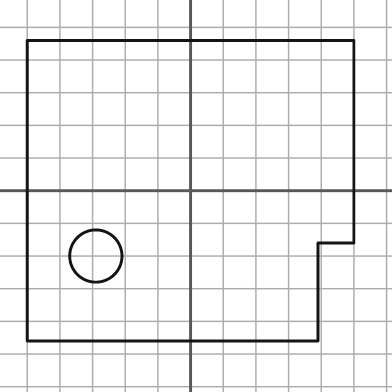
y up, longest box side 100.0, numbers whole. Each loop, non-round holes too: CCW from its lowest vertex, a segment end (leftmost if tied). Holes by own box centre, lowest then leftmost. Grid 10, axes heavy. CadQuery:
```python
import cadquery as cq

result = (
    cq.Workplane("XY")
    .moveTo(-50.0, -46.0)
    .lineTo(39.0, -46.0)
    .lineTo(39.0, -16.0)
    .lineTo(50.0, -16.0)
    .lineTo(50.0, 46.0)
    .lineTo(-50.0, 46.0)
    .close()
    .moveTo(-29.0, -20.0)
    .circle(8.0)
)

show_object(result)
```